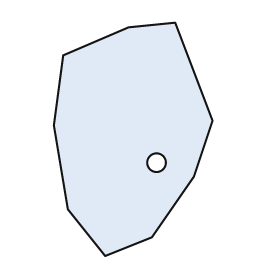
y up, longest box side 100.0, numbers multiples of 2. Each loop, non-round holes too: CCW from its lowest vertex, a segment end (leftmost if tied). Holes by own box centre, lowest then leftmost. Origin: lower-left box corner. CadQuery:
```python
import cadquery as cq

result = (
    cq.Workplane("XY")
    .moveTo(22.0, 0.0)
    .lineTo(42.0, 8.0)
    .lineTo(60.0, 34.0)
    .lineTo(68.0, 58.0)
    .lineTo(52.0, 100.0)
    .lineTo(32.0, 98.0)
    .lineTo(4.0, 86.0)
    .lineTo(0.0, 56.0)
    .lineTo(6.0, 20.0)
    .close()
    .moveTo(44.0, 40.0)
    .circle(4.0)
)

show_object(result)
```